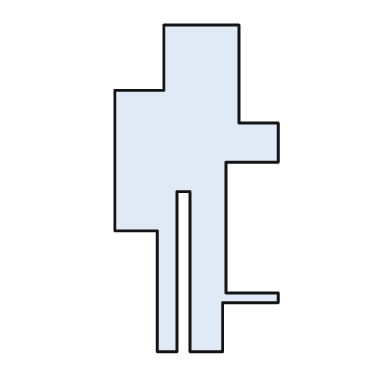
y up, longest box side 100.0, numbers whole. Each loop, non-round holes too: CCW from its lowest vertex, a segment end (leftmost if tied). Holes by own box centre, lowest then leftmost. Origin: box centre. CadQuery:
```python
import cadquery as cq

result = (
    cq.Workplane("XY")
    .moveTo(-12.0, -50.0)
    .lineTo(-6.0, -50.0)
    .lineTo(-6.0, -1.0)
    .lineTo(-2.0, -1.0)
    .lineTo(-2.0, -50.0)
    .lineTo(8.0, -50.0)
    .lineTo(8.0, -35.0)
    .lineTo(25.0, -35.0)
    .lineTo(25.0, -32.0)
    .lineTo(9.0, -32.0)
    .lineTo(9.0, 8.0)
    .lineTo(25.0, 8.0)
    .lineTo(25.0, 20.0)
    .lineTo(13.0, 20.0)
    .lineTo(13.0, 50.0)
    .lineTo(-10.0, 50.0)
    .lineTo(-10.0, 30.0)
    .lineTo(-25.0, 30.0)
    .lineTo(-25.0, -13.0)
    .lineTo(-12.0, -13.0)
    .close()
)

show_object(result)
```